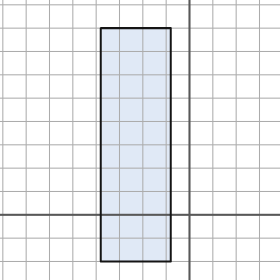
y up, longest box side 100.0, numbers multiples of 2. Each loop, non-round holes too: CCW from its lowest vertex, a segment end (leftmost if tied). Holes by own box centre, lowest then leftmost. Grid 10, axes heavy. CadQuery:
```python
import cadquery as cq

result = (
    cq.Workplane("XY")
    .moveTo(-38.0, -20.0)
    .lineTo(-8.0, -20.0)
    .lineTo(-8.0, 80.0)
    .lineTo(-38.0, 80.0)
    .close()
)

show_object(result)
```